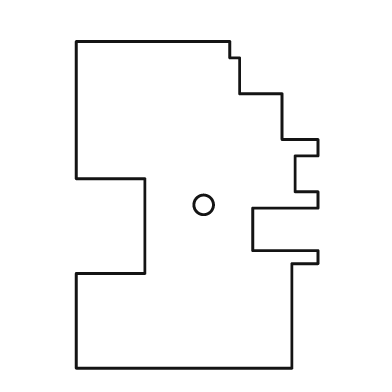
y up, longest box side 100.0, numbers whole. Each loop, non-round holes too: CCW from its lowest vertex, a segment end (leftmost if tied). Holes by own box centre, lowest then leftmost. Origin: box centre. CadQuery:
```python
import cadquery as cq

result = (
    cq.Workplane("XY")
    .moveTo(-37.0, -50.0)
    .lineTo(29.0, -50.0)
    .lineTo(29.0, -18.0)
    .lineTo(37.0, -18.0)
    .lineTo(37.0, -14.0)
    .lineTo(17.0, -14.0)
    .lineTo(17.0, -1.0)
    .lineTo(37.0, -1.0)
    .lineTo(37.0, 4.0)
    .lineTo(30.0, 4.0)
    .lineTo(30.0, 15.0)
    .lineTo(37.0, 15.0)
    .lineTo(37.0, 20.0)
    .lineTo(26.0, 20.0)
    .lineTo(26.0, 34.0)
    .lineTo(13.0, 34.0)
    .lineTo(13.0, 45.0)
    .lineTo(10.0, 45.0)
    .lineTo(10.0, 50.0)
    .lineTo(-37.0, 50.0)
    .lineTo(-37.0, 8.0)
    .lineTo(-16.0, 8.0)
    .lineTo(-16.0, -21.0)
    .lineTo(-37.0, -21.0)
    .close()
    .moveTo(2.0, 0.0)
    .circle(3.0)
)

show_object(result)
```